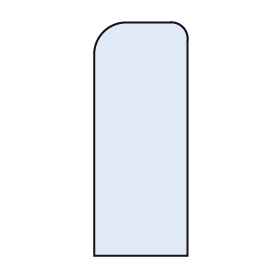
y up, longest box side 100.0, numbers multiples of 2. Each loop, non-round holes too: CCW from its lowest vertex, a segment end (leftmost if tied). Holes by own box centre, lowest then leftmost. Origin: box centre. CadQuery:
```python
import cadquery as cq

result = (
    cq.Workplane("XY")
    .moveTo(-20.0, -50.0)
    .lineTo(20.0, -50.0)
    .lineTo(20.0, 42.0)
    .threePointArc((18.0, 48.0), (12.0, 50.0))
    .lineTo(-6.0, 50.0)
    .threePointArc((-16.0, 46.0), (-20.0, 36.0))
    .close()
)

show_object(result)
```